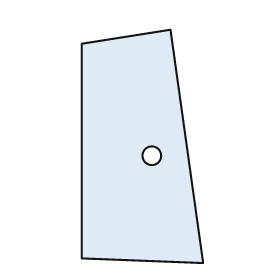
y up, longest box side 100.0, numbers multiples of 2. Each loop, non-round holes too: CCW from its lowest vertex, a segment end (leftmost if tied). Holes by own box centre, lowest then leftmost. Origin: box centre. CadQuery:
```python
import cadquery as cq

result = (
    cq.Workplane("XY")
    .moveTo(26.0, -50.0)
    .lineTo(12.0, 50.0)
    .lineTo(-26.0, 44.0)
    .lineTo(-26.0, -48.0)
    .close()
    .moveTo(4.0, -4.0)
    .circle(4.0)
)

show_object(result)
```